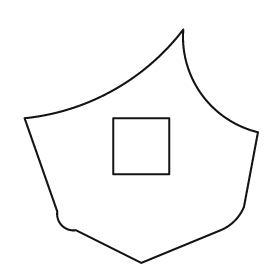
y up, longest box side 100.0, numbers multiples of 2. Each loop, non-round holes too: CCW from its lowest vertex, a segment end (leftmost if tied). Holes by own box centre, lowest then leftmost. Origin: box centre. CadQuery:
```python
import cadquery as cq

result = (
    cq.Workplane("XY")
    .moveTo(0.0, -50.0)
    .lineTo(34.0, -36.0)
    .threePointArc((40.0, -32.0), (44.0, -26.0))
    .lineTo(50.0, 6.0)
    .threePointArc((26.0, 22.0), (18.0, 50.0))
    .threePointArc((-12.0, 24.0), (-50.0, 12.0))
    .lineTo(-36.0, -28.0)
    .threePointArc((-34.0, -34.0), (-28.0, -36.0))
    .close()
    .moveTo(-12.0, -12.0)
    .lineTo(12.0, -12.0)
    .lineTo(12.0, 12.0)
    .lineTo(-12.0, 12.0)
    .close()
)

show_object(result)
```